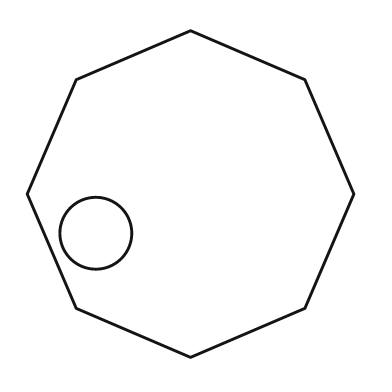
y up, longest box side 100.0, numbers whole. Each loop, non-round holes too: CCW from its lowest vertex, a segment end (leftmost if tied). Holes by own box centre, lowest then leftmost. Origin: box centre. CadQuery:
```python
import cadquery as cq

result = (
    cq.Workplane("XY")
    .moveTo(0.0, -50.0)
    .lineTo(35.0, -35.0)
    .lineTo(50.0, 0.0)
    .lineTo(35.0, 35.0)
    .lineTo(0.0, 50.0)
    .lineTo(-35.0, 35.0)
    .lineTo(-50.0, 0.0)
    .lineTo(-35.0, -35.0)
    .close()
    .moveTo(-29.0, -12.0)
    .circle(11.0)
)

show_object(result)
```